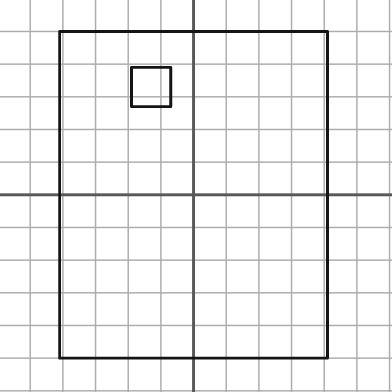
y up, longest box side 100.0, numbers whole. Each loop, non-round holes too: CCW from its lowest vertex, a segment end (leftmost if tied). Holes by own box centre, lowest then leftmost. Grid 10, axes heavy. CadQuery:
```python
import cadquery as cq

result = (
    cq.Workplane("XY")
    .moveTo(-41.0, -50.0)
    .lineTo(41.0, -50.0)
    .lineTo(41.0, 50.0)
    .lineTo(-41.0, 50.0)
    .close()
    .moveTo(-19.0, 27.0)
    .lineTo(-7.0, 27.0)
    .lineTo(-7.0, 39.0)
    .lineTo(-19.0, 39.0)
    .close()
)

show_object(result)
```